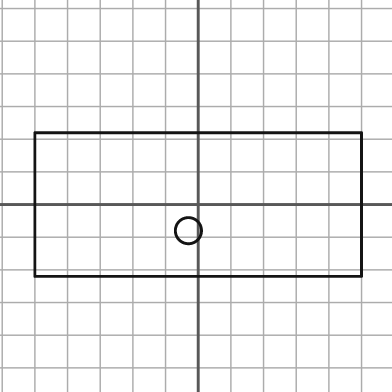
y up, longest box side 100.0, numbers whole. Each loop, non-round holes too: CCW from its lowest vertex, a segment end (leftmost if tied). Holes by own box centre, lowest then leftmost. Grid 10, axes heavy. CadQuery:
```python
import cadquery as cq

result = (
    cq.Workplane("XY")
    .moveTo(-50.0, -22.0)
    .lineTo(50.0, -22.0)
    .lineTo(50.0, 22.0)
    .lineTo(-50.0, 22.0)
    .close()
    .moveTo(-3.0, -8.0)
    .circle(4.0)
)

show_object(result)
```